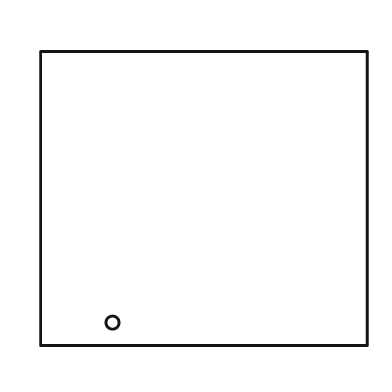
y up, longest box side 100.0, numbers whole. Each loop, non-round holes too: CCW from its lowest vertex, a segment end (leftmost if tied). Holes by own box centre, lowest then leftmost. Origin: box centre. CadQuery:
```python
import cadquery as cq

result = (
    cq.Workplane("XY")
    .moveTo(-50.0, -45.0)
    .lineTo(50.0, -45.0)
    .lineTo(50.0, 45.0)
    .lineTo(-50.0, 45.0)
    .close()
    .moveTo(-28.0, -38.0)
    .circle(2.0)
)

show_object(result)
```